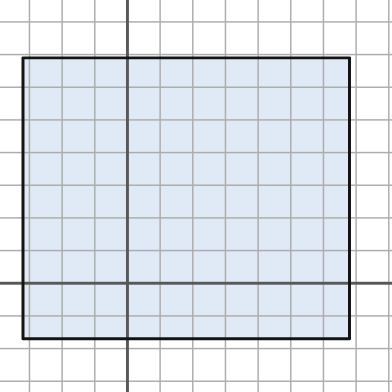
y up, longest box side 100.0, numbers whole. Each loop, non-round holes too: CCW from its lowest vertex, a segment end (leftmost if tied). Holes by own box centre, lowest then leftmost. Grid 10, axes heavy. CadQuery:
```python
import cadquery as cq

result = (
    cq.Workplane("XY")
    .moveTo(-32.0, -17.0)
    .lineTo(68.0, -17.0)
    .lineTo(68.0, 69.0)
    .lineTo(-32.0, 69.0)
    .close()
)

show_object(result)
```